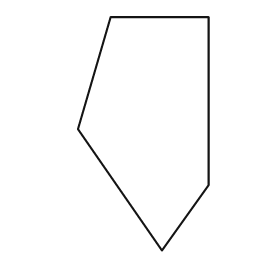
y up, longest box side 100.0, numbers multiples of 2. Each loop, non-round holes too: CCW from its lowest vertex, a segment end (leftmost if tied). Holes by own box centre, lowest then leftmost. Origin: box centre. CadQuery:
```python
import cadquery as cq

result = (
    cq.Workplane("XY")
    .moveTo(8.0, -50.0)
    .lineTo(28.0, -22.0)
    .lineTo(28.0, 50.0)
    .lineTo(-14.0, 50.0)
    .lineTo(-28.0, 2.0)
    .close()
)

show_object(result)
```